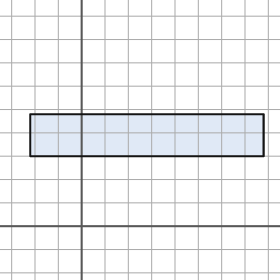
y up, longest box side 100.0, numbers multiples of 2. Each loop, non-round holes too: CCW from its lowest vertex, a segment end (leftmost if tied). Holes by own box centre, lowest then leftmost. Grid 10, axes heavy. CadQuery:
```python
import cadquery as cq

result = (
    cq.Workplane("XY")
    .moveTo(-22.0, 30.0)
    .lineTo(78.0, 30.0)
    .lineTo(78.0, 48.0)
    .lineTo(-22.0, 48.0)
    .close()
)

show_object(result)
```